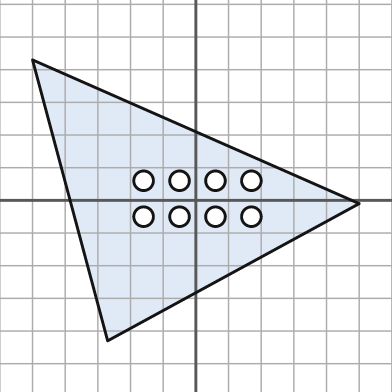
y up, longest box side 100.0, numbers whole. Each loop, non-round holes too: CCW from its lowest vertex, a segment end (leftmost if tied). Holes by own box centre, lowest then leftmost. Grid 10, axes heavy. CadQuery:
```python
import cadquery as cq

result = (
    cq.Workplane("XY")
    .moveTo(-27.0, -43.0)
    .lineTo(50.0, -1.0)
    .lineTo(-50.0, 43.0)
    .close()
    .moveTo(-16.0, -5.0)
    .circle(3.0)
    .moveTo(-5.0, -5.0)
    .circle(3.0)
    .moveTo(6.0, -5.0)
    .circle(3.0)
    .moveTo(17.0, -5.0)
    .circle(3.0)
    .moveTo(-16.0, 6.0)
    .circle(3.0)
    .moveTo(-5.0, 6.0)
    .circle(3.0)
    .moveTo(6.0, 6.0)
    .circle(3.0)
    .moveTo(17.0, 6.0)
    .circle(3.0)
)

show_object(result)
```